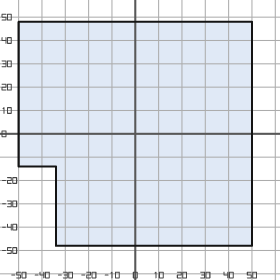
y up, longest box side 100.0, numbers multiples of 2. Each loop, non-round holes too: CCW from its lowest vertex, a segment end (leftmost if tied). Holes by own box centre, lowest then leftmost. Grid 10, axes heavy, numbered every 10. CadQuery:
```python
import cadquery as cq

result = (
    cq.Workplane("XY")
    .moveTo(-34.0, -48.0)
    .lineTo(50.0, -48.0)
    .lineTo(50.0, 48.0)
    .lineTo(-50.0, 48.0)
    .lineTo(-50.0, -14.0)
    .lineTo(-34.0, -14.0)
    .close()
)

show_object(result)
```